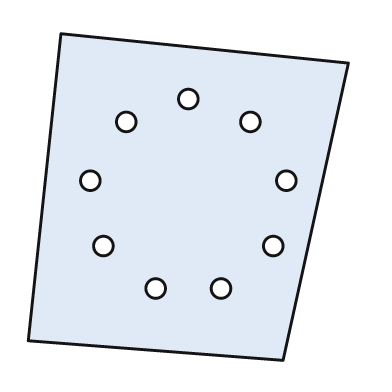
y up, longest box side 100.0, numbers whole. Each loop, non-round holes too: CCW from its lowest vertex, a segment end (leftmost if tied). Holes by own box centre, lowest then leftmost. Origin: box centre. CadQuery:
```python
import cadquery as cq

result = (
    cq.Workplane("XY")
    .moveTo(29.0, -50.0)
    .lineTo(49.0, 41.0)
    .lineTo(-39.0, 50.0)
    .lineTo(-49.0, -44.0)
    .close()
    .moveTo(-10.0, -28.0)
    .circle(3.0)
    .moveTo(10.0, -28.0)
    .circle(3.0)
    .moveTo(-26.0, -15.0)
    .circle(3.0)
    .moveTo(26.0, -15.0)
    .circle(3.0)
    .moveTo(-30.0, 5.0)
    .circle(3.0)
    .moveTo(30.0, 5.0)
    .circle(3.0)
    .moveTo(-19.0, 23.0)
    .circle(3.0)
    .moveTo(19.0, 23.0)
    .circle(3.0)
    .moveTo(0.0, 30.0)
    .circle(3.0)
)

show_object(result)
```